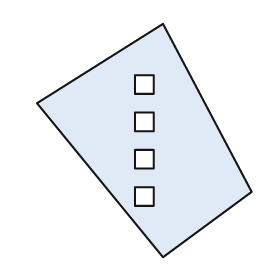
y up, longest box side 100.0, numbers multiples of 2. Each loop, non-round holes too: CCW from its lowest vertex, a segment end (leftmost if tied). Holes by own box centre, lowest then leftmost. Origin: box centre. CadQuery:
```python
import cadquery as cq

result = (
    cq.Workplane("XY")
    .moveTo(8.0, -50.0)
    .lineTo(46.0, -22.0)
    .lineTo(8.0, 50.0)
    .lineTo(-46.0, 16.0)
    .close()
    .moveTo(-4.0, -28.0)
    .lineTo(4.0, -28.0)
    .lineTo(4.0, -20.0)
    .lineTo(-4.0, -20.0)
    .close()
    .moveTo(-4.0, -12.0)
    .lineTo(4.0, -12.0)
    .lineTo(4.0, -4.0)
    .lineTo(-4.0, -4.0)
    .close()
    .moveTo(-4.0, 4.0)
    .lineTo(4.0, 4.0)
    .lineTo(4.0, 12.0)
    .lineTo(-4.0, 12.0)
    .close()
    .moveTo(-4.0, 20.0)
    .lineTo(4.0, 20.0)
    .lineTo(4.0, 28.0)
    .lineTo(-4.0, 28.0)
    .close()
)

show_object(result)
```